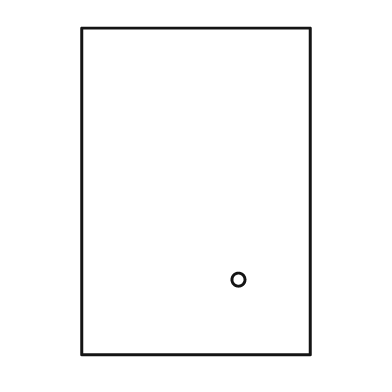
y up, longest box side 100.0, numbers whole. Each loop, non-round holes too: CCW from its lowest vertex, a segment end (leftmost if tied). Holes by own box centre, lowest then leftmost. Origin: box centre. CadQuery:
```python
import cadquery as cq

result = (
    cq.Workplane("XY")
    .moveTo(-35.0, -50.0)
    .lineTo(35.0, -50.0)
    .lineTo(35.0, 50.0)
    .lineTo(-35.0, 50.0)
    .close()
    .moveTo(13.0, -27.0)
    .circle(2.0)
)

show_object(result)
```